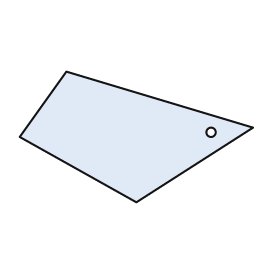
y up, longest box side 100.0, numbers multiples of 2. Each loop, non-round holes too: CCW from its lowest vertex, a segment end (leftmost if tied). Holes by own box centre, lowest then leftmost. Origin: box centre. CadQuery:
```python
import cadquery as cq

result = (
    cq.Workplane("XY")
    .moveTo(0.0, -28.0)
    .lineTo(50.0, 4.0)
    .lineTo(-30.0, 28.0)
    .lineTo(-50.0, 0.0)
    .close()
    .moveTo(32.0, 2.0)
    .circle(2.0)
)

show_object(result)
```